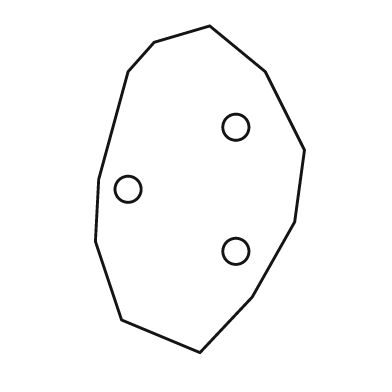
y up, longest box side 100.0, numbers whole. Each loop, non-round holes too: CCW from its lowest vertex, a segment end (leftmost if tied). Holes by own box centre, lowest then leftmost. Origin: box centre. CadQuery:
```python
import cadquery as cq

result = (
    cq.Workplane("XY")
    .moveTo(0.0, -50.0)
    .lineTo(16.0, -33.0)
    .lineTo(29.0, -10.0)
    .lineTo(32.0, 12.0)
    .lineTo(20.0, 36.0)
    .lineTo(3.0, 50.0)
    .lineTo(-14.0, 45.0)
    .lineTo(-22.0, 36.0)
    .lineTo(-31.0, 3.0)
    .lineTo(-32.0, -16.0)
    .lineTo(-24.0, -40.0)
    .close()
    .moveTo(11.0, -19.0)
    .circle(4.0)
    .moveTo(-22.0, 0.0)
    .circle(4.0)
    .moveTo(11.0, 19.0)
    .circle(4.0)
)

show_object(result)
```